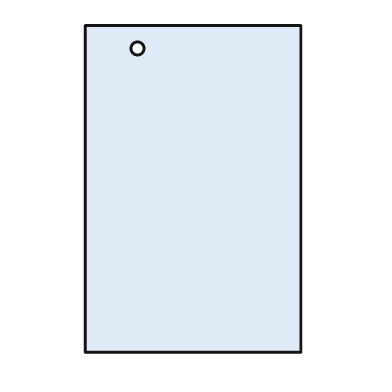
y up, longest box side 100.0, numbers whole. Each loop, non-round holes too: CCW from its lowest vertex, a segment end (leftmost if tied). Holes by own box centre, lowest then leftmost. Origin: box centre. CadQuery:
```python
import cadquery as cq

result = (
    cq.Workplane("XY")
    .moveTo(-33.0, -50.0)
    .lineTo(33.0, -50.0)
    .lineTo(33.0, 50.0)
    .lineTo(-33.0, 50.0)
    .close()
    .moveTo(-17.0, 43.0)
    .circle(2.0)
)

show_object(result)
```